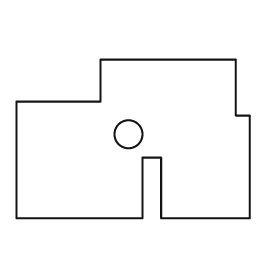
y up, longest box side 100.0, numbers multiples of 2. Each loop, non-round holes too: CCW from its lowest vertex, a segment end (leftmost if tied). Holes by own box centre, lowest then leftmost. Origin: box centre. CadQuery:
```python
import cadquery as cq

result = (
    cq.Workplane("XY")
    .moveTo(-50.0, -34.0)
    .lineTo(4.0, -34.0)
    .lineTo(4.0, -8.0)
    .lineTo(12.0, -8.0)
    .lineTo(12.0, -34.0)
    .lineTo(50.0, -34.0)
    .lineTo(50.0, 10.0)
    .lineTo(44.0, 10.0)
    .lineTo(44.0, 34.0)
    .lineTo(-14.0, 34.0)
    .lineTo(-14.0, 16.0)
    .lineTo(-50.0, 16.0)
    .close()
    .moveTo(-2.0, 2.0)
    .circle(6.0)
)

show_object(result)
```